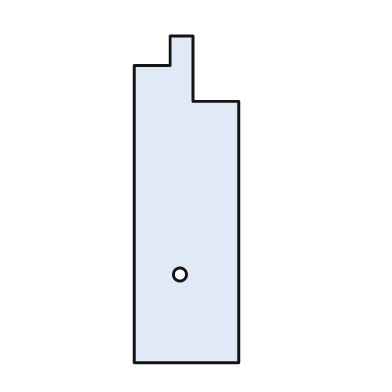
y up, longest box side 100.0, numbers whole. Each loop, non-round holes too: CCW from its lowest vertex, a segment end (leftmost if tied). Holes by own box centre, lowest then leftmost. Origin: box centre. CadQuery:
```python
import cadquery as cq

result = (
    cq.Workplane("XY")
    .moveTo(-16.0, -50.0)
    .lineTo(16.0, -50.0)
    .lineTo(16.0, 30.0)
    .lineTo(2.0, 30.0)
    .lineTo(2.0, 50.0)
    .lineTo(-5.0, 50.0)
    .lineTo(-5.0, 41.0)
    .lineTo(-16.0, 41.0)
    .close()
    .moveTo(-2.0, -23.0)
    .circle(2.0)
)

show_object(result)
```